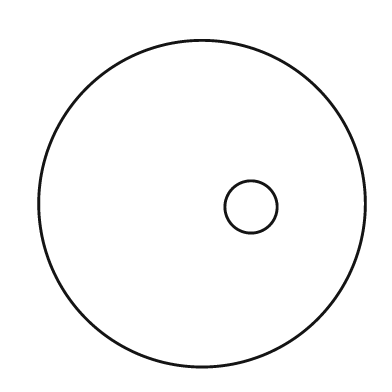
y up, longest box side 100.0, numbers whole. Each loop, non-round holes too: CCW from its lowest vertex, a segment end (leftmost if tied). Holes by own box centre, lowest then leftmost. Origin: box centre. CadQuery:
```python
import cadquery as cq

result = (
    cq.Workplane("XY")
    .moveTo(0.0, 0.0)
    .circle(50.0)
    .moveTo(15.0, -1.0)
    .circle(8.0)
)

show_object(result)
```